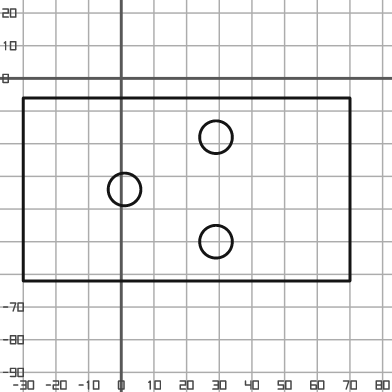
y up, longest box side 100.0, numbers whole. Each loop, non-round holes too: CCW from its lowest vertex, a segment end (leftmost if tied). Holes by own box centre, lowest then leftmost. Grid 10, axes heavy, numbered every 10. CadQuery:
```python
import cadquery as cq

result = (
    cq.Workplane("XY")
    .moveTo(-30.0, -62.0)
    .lineTo(70.0, -62.0)
    .lineTo(70.0, -6.0)
    .lineTo(-30.0, -6.0)
    .close()
    .moveTo(29.0, -50.0)
    .circle(5.0)
    .moveTo(1.0, -34.0)
    .circle(5.0)
    .moveTo(29.0, -18.0)
    .circle(5.0)
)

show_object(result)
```